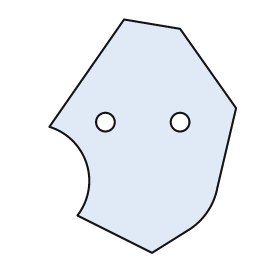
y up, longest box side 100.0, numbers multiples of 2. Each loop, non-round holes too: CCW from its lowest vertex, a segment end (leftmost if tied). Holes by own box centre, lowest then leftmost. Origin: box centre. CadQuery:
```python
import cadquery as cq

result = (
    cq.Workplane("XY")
    .moveTo(4.0, -50.0)
    .lineTo(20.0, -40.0)
    .threePointArc((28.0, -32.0), (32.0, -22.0))
    .lineTo(40.0, 12.0)
    .lineTo(16.0, 46.0)
    .lineTo(-8.0, 50.0)
    .lineTo(-40.0, 4.0)
    .threePointArc((-24.0, -12.0), (-28.0, -34.0))
    .close()
    .moveTo(-16.0, 6.0)
    .circle(4.0)
    .moveTo(16.0, 6.0)
    .circle(4.0)
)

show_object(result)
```